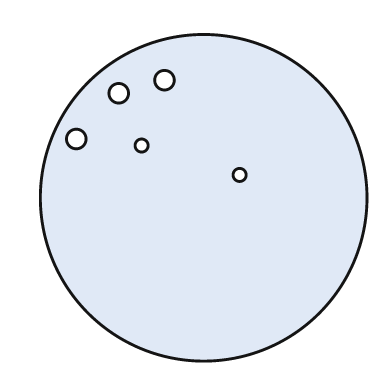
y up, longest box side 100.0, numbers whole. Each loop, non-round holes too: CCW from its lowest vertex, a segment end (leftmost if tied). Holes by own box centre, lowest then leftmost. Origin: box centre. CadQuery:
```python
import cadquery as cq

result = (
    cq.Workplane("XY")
    .moveTo(0.0, 0.0)
    .circle(50.0)
    .moveTo(11.0, 7.0)
    .circle(2.0)
    .moveTo(-19.0, 16.0)
    .circle(2.0)
    .moveTo(-39.0, 18.0)
    .circle(3.0)
    .moveTo(-26.0, 32.0)
    .circle(3.0)
    .moveTo(-12.0, 36.0)
    .circle(3.0)
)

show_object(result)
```